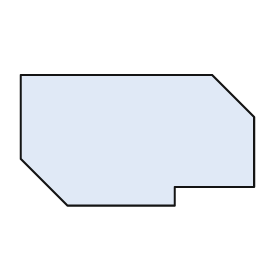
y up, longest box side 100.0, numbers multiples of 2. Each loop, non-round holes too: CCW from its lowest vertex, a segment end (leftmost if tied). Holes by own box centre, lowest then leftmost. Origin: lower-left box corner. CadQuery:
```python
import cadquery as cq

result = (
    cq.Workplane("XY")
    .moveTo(20.0, 0.0)
    .lineTo(66.0, 0.0)
    .lineTo(66.0, 8.0)
    .lineTo(100.0, 8.0)
    .lineTo(100.0, 38.0)
    .lineTo(82.0, 56.0)
    .lineTo(0.0, 56.0)
    .lineTo(0.0, 20.0)
    .close()
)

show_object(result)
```